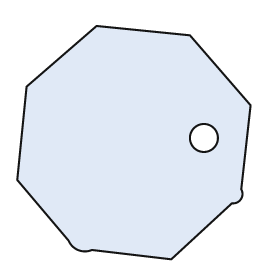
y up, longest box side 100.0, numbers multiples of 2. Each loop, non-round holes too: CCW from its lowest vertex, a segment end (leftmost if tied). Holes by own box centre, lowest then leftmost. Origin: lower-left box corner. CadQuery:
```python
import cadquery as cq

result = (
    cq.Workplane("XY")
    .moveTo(66.0, 0.0)
    .lineTo(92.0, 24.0)
    .threePointArc((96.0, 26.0), (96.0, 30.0))
    .lineTo(100.0, 66.0)
    .lineTo(74.0, 96.0)
    .lineTo(34.0, 100.0)
    .lineTo(4.0, 74.0)
    .lineTo(0.0, 34.0)
    .lineTo(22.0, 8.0)
    .threePointArc((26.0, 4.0), (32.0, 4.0))
    .close()
    .moveTo(80.0, 52.0)
    .circle(6.0)
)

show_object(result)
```